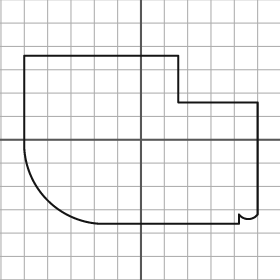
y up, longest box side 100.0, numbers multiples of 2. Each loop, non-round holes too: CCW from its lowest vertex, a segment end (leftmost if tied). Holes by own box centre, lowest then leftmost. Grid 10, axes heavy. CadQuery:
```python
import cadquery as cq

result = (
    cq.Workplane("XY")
    .moveTo(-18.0, -36.0)
    .lineTo(42.0, -36.0)
    .lineTo(42.0, -32.0)
    .threePointArc((46.0, -34.0), (50.0, -32.0))
    .lineTo(50.0, 16.0)
    .lineTo(16.0, 16.0)
    .lineTo(16.0, 36.0)
    .lineTo(-50.0, 36.0)
    .lineTo(-50.0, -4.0)
    .threePointArc((-40.0, -26.0), (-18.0, -36.0))
    .close()
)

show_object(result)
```